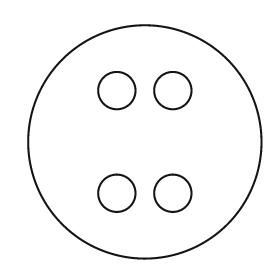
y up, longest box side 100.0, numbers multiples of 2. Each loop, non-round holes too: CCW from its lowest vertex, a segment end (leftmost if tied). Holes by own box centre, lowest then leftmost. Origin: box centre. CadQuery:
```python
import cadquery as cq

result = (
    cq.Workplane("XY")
    .moveTo(0.0, 0.0)
    .circle(50.0)
    .moveTo(-12.0, -22.0)
    .circle(8.0)
    .moveTo(12.0, -22.0)
    .circle(8.0)
    .moveTo(-12.0, 22.0)
    .circle(8.0)
    .moveTo(12.0, 22.0)
    .circle(8.0)
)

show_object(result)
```